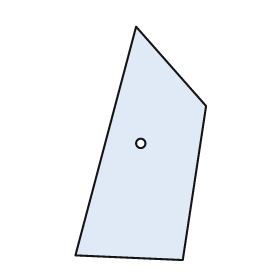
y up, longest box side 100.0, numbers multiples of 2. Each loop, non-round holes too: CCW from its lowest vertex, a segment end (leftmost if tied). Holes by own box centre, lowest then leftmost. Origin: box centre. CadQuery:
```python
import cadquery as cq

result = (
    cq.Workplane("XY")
    .moveTo(18.0, -50.0)
    .lineTo(28.0, 16.0)
    .lineTo(-2.0, 50.0)
    .lineTo(-28.0, -48.0)
    .close()
    .moveTo(0.0, 0.0)
    .circle(2.0)
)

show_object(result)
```